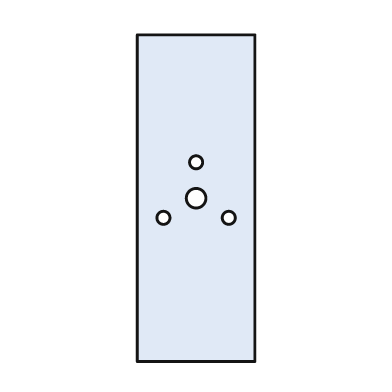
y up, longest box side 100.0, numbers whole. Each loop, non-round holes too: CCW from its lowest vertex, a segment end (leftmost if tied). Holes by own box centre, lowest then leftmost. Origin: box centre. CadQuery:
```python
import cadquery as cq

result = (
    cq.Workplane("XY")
    .moveTo(-18.0, -50.0)
    .lineTo(18.0, -50.0)
    .lineTo(18.0, 50.0)
    .lineTo(-18.0, 50.0)
    .close()
    .moveTo(-10.0, -6.0)
    .circle(2.0)
    .moveTo(10.0, -6.0)
    .circle(2.0)
    .moveTo(0.0, 0.0)
    .circle(3.0)
    .moveTo(0.0, 11.0)
    .circle(2.0)
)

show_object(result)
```